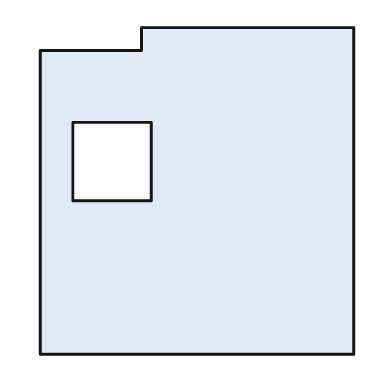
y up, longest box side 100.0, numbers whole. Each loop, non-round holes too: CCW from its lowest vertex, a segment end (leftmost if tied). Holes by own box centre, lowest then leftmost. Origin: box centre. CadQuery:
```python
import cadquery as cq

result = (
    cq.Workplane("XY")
    .moveTo(-48.0, -50.0)
    .lineTo(48.0, -50.0)
    .lineTo(48.0, 50.0)
    .lineTo(-17.0, 50.0)
    .lineTo(-17.0, 43.0)
    .lineTo(-48.0, 43.0)
    .close()
    .moveTo(-38.0, -3.0)
    .lineTo(-14.0, -3.0)
    .lineTo(-14.0, 21.0)
    .lineTo(-38.0, 21.0)
    .close()
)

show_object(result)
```